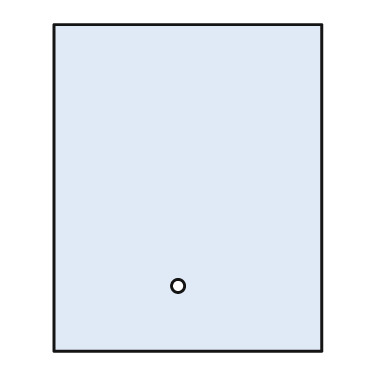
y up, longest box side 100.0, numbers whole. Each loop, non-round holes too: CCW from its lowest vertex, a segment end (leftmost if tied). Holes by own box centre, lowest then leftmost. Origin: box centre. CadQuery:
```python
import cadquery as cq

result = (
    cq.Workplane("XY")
    .moveTo(-41.0, -50.0)
    .lineTo(41.0, -50.0)
    .lineTo(41.0, 50.0)
    .lineTo(-41.0, 50.0)
    .close()
    .moveTo(-3.0, -30.0)
    .circle(2.0)
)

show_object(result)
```